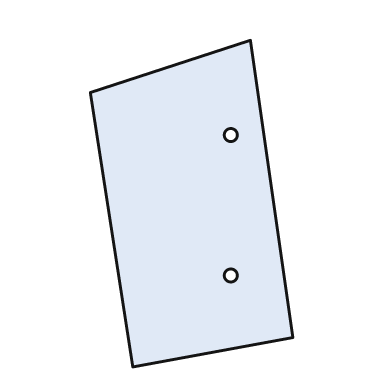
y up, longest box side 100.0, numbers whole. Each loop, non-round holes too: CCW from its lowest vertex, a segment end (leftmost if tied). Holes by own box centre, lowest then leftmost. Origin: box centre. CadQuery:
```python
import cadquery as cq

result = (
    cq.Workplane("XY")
    .moveTo(-18.0, -50.0)
    .lineTo(31.0, -41.0)
    .lineTo(18.0, 50.0)
    .lineTo(-31.0, 34.0)
    .close()
    .moveTo(12.0, -22.0)
    .circle(2.0)
    .moveTo(12.0, 21.0)
    .circle(2.0)
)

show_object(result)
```